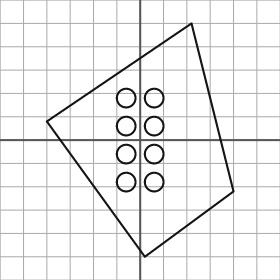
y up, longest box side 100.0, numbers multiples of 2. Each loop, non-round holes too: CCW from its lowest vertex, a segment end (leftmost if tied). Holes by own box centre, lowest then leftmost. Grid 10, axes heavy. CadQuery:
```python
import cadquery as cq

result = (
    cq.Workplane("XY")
    .moveTo(2.0, -50.0)
    .lineTo(40.0, -22.0)
    .lineTo(22.0, 50.0)
    .lineTo(-40.0, 8.0)
    .close()
    .moveTo(-6.0, -18.0)
    .circle(4.0)
    .moveTo(6.0, -18.0)
    .circle(4.0)
    .moveTo(-6.0, -6.0)
    .circle(4.0)
    .moveTo(6.0, -6.0)
    .circle(4.0)
    .moveTo(-6.0, 6.0)
    .circle(4.0)
    .moveTo(6.0, 6.0)
    .circle(4.0)
    .moveTo(-6.0, 18.0)
    .circle(4.0)
    .moveTo(6.0, 18.0)
    .circle(4.0)
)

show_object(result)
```